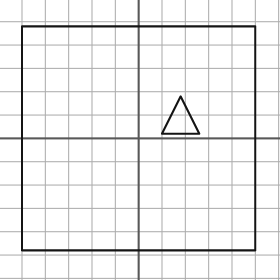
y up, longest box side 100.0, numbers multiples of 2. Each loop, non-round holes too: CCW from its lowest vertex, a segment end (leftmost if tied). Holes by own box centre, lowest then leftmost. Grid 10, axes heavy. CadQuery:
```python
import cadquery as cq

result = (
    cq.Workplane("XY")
    .moveTo(-50.0, -48.0)
    .lineTo(50.0, -48.0)
    .lineTo(50.0, 48.0)
    .lineTo(-50.0, 48.0)
    .close()
    .moveTo(10.0, 2.0)
    .lineTo(26.0, 2.0)
    .lineTo(18.0, 18.0)
    .close()
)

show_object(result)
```